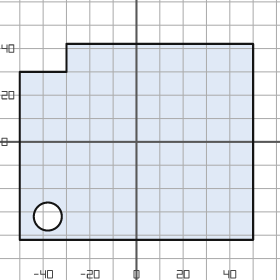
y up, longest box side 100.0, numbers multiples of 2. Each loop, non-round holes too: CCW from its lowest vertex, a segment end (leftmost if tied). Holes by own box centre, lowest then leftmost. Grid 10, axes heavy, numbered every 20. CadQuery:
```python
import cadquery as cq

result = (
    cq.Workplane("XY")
    .moveTo(-50.0, -42.0)
    .lineTo(50.0, -42.0)
    .lineTo(50.0, 42.0)
    .lineTo(-30.0, 42.0)
    .lineTo(-30.0, 30.0)
    .lineTo(-50.0, 30.0)
    .close()
    .moveTo(-38.0, -32.0)
    .circle(6.0)
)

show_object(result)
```